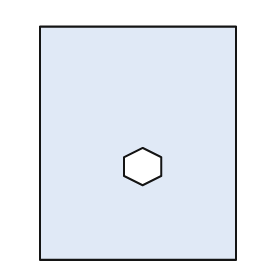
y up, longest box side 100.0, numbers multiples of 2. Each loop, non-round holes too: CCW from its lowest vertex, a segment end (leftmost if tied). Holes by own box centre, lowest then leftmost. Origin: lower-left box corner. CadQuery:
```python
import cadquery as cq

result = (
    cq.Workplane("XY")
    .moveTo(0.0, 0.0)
    .lineTo(84.0, 0.0)
    .lineTo(84.0, 100.0)
    .lineTo(0.0, 100.0)
    .close()
    .moveTo(44.0, 32.0)
    .lineTo(52.0, 36.0)
    .lineTo(52.0, 44.0)
    .lineTo(44.0, 48.0)
    .lineTo(36.0, 44.0)
    .lineTo(36.0, 36.0)
    .close()
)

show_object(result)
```